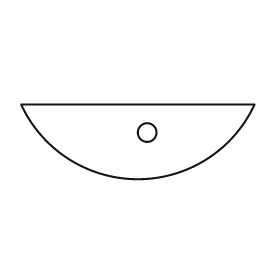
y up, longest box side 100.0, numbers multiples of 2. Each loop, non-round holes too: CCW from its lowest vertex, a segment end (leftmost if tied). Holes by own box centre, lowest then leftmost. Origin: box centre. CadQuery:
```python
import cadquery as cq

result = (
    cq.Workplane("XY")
    .moveTo(-50.0, 16.0)
    .threePointArc((0.0, -16.0), (50.0, 16.0))
    .close()
    .moveTo(4.0, 4.0)
    .circle(4.0)
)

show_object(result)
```